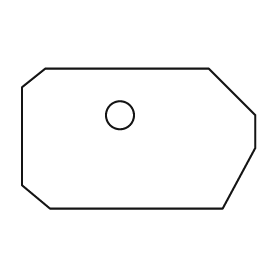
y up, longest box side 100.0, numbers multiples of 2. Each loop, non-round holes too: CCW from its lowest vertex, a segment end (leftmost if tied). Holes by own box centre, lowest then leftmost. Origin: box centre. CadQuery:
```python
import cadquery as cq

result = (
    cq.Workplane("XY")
    .moveTo(-38.0, -30.0)
    .lineTo(36.0, -30.0)
    .lineTo(50.0, -4.0)
    .lineTo(50.0, 10.0)
    .lineTo(30.0, 30.0)
    .lineTo(-40.0, 30.0)
    .lineTo(-50.0, 22.0)
    .lineTo(-50.0, -20.0)
    .close()
    .moveTo(-8.0, 10.0)
    .circle(6.0)
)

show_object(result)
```